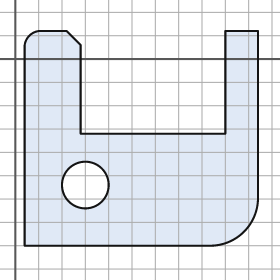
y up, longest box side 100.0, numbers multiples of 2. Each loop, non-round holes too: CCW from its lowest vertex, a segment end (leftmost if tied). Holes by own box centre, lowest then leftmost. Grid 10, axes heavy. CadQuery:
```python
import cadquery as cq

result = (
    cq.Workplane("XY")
    .moveTo(4.0, -80.0)
    .lineTo(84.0, -80.0)
    .threePointArc((98.0, -74.0), (104.0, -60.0))
    .lineTo(104.0, 12.0)
    .lineTo(90.0, 12.0)
    .lineTo(90.0, -32.0)
    .lineTo(28.0, -32.0)
    .lineTo(28.0, 6.0)
    .lineTo(22.0, 12.0)
    .lineTo(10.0, 12.0)
    .threePointArc((6.0, 10.0), (4.0, 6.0))
    .close()
    .moveTo(30.0, -54.0)
    .circle(10.0)
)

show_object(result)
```